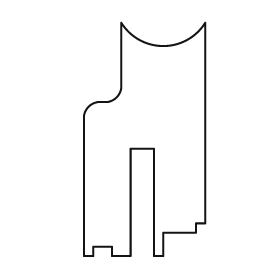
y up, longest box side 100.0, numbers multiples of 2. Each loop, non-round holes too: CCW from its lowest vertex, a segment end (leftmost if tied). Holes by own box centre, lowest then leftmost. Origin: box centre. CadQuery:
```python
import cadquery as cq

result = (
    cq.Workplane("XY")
    .moveTo(-26.0, -50.0)
    .lineTo(-22.0, -50.0)
    .lineTo(-22.0, -46.0)
    .lineTo(-14.0, -46.0)
    .lineTo(-14.0, -50.0)
    .lineTo(-6.0, -50.0)
    .lineTo(-6.0, -4.0)
    .lineTo(4.0, -4.0)
    .lineTo(4.0, -50.0)
    .lineTo(8.0, -50.0)
    .lineTo(8.0, -40.0)
    .lineTo(22.0, -40.0)
    .lineTo(22.0, -36.0)
    .lineTo(26.0, -36.0)
    .lineTo(26.0, 50.0)
    .threePointArc((8.0, 40.0), (-10.0, 50.0))
    .lineTo(-10.0, 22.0)
    .threePointArc((-12.0, 18.0), (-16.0, 16.0))
    .lineTo(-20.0, 16.0)
    .threePointArc((-24.0, 14.0), (-26.0, 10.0))
    .close()
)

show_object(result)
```